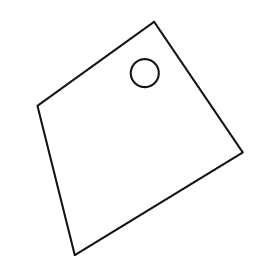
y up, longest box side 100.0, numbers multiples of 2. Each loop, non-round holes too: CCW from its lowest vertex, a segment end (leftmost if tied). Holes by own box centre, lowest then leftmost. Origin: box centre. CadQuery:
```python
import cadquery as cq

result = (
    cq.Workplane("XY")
    .moveTo(-28.0, -50.0)
    .lineTo(44.0, -6.0)
    .lineTo(6.0, 50.0)
    .lineTo(-44.0, 14.0)
    .close()
    .moveTo(2.0, 28.0)
    .circle(6.0)
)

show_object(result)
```